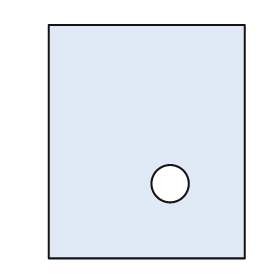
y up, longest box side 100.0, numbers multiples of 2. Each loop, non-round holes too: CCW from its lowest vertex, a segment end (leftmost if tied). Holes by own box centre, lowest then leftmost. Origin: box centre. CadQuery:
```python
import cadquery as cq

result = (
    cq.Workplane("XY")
    .moveTo(-42.0, -50.0)
    .lineTo(42.0, -50.0)
    .lineTo(42.0, 50.0)
    .lineTo(-42.0, 50.0)
    .close()
    .moveTo(10.0, -18.0)
    .circle(8.0)
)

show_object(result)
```